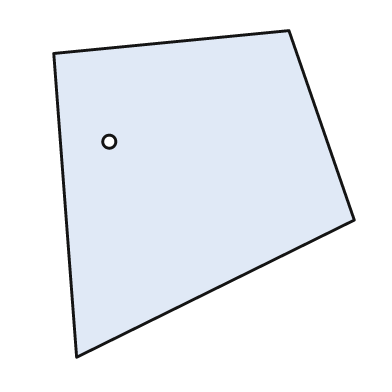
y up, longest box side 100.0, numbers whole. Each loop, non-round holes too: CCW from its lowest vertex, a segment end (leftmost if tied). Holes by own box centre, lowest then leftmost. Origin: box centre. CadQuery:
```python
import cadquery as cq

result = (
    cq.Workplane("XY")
    .moveTo(-39.0, -50.0)
    .lineTo(46.0, -8.0)
    .lineTo(26.0, 50.0)
    .lineTo(-46.0, 43.0)
    .close()
    .moveTo(-29.0, 16.0)
    .circle(2.0)
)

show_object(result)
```